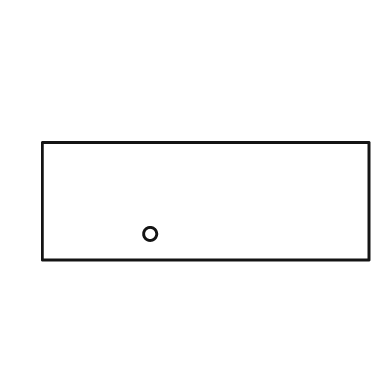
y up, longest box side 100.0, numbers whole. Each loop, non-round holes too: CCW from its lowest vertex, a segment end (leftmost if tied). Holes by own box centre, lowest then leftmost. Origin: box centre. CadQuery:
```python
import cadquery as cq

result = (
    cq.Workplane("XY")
    .moveTo(-50.0, -18.0)
    .lineTo(50.0, -18.0)
    .lineTo(50.0, 18.0)
    .lineTo(-50.0, 18.0)
    .close()
    .moveTo(-17.0, -10.0)
    .circle(2.0)
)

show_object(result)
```